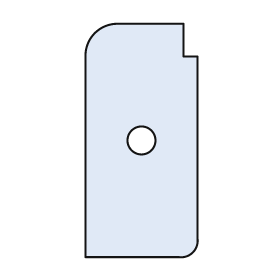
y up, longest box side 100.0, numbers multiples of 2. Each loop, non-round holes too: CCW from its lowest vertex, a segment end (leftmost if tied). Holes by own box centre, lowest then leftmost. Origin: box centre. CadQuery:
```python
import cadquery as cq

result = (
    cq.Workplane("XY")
    .moveTo(-24.0, -50.0)
    .lineTo(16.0, -50.0)
    .threePointArc((22.0, -48.0), (24.0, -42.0))
    .lineTo(24.0, 36.0)
    .lineTo(18.0, 36.0)
    .lineTo(18.0, 50.0)
    .lineTo(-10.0, 50.0)
    .threePointArc((-20.0, 46.0), (-24.0, 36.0))
    .close()
    .moveTo(0.0, 0.0)
    .circle(6.0)
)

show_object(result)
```